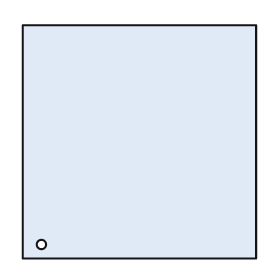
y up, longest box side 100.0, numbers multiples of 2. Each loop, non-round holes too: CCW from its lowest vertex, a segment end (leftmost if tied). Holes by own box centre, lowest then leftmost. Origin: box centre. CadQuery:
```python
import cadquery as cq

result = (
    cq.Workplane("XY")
    .moveTo(-50.0, -50.0)
    .lineTo(50.0, -50.0)
    .lineTo(50.0, 50.0)
    .lineTo(-50.0, 50.0)
    .close()
    .moveTo(-42.0, -44.0)
    .circle(2.0)
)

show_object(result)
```